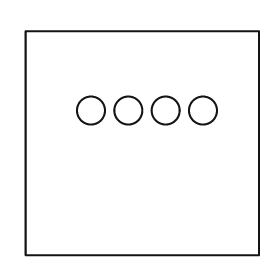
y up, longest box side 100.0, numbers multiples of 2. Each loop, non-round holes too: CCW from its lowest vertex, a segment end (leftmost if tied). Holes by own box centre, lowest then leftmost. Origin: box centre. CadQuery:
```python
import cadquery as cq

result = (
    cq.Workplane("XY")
    .moveTo(-50.0, -48.0)
    .lineTo(50.0, -48.0)
    .lineTo(50.0, 48.0)
    .lineTo(-50.0, 48.0)
    .close()
    .moveTo(-22.0, 14.0)
    .circle(6.0)
    .moveTo(-6.0, 14.0)
    .circle(6.0)
    .moveTo(10.0, 14.0)
    .circle(6.0)
    .moveTo(26.0, 14.0)
    .circle(6.0)
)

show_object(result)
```